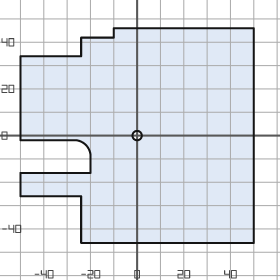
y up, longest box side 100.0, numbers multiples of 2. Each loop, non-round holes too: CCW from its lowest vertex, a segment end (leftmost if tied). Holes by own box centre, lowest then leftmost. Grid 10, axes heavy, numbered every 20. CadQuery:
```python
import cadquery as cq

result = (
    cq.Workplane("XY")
    .moveTo(-24.0, -46.0)
    .lineTo(50.0, -46.0)
    .lineTo(50.0, 46.0)
    .lineTo(-10.0, 46.0)
    .lineTo(-10.0, 42.0)
    .lineTo(-24.0, 42.0)
    .lineTo(-24.0, 34.0)
    .lineTo(-50.0, 34.0)
    .lineTo(-50.0, -2.0)
    .lineTo(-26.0, -2.0)
    .threePointArc((-22.0, -4.0), (-20.0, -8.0))
    .lineTo(-20.0, -16.0)
    .lineTo(-50.0, -16.0)
    .lineTo(-50.0, -26.0)
    .lineTo(-24.0, -26.0)
    .close()
    .moveTo(0.0, 0.0)
    .circle(2.0)
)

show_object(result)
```